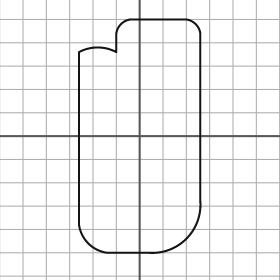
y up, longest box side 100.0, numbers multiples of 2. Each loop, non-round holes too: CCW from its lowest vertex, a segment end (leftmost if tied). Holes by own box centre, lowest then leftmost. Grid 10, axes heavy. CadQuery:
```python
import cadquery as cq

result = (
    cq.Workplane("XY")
    .moveTo(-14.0, -50.0)
    .lineTo(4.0, -50.0)
    .threePointArc((20.0, -44.0), (26.0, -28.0))
    .lineTo(26.0, 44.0)
    .threePointArc((24.0, 48.0), (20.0, 50.0))
    .lineTo(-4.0, 50.0)
    .threePointArc((-8.0, 48.0), (-10.0, 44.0))
    .lineTo(-10.0, 36.0)
    .threePointArc((-18.0, 38.0), (-26.0, 36.0))
    .lineTo(-26.0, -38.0)
    .threePointArc((-22.0, -46.0), (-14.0, -50.0))
    .close()
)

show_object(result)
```